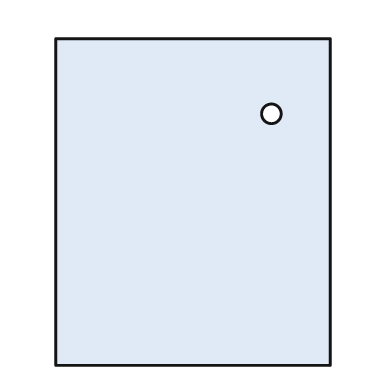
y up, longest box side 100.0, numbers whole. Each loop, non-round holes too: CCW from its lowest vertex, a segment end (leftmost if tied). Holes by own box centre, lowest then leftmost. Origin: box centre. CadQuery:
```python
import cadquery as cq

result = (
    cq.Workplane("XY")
    .moveTo(-42.0, -50.0)
    .lineTo(42.0, -50.0)
    .lineTo(42.0, 50.0)
    .lineTo(-42.0, 50.0)
    .close()
    .moveTo(24.0, 27.0)
    .circle(3.0)
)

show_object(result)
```